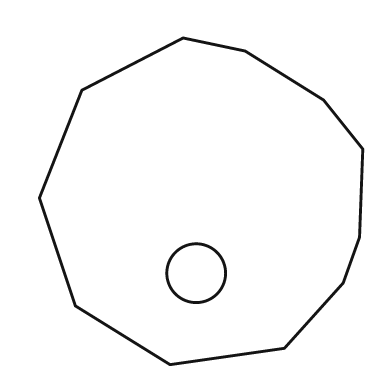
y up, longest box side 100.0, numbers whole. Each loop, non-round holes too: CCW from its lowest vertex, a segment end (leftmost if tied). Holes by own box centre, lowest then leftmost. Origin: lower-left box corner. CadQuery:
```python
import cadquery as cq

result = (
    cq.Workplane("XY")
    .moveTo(40.0, 0.0)
    .lineTo(75.0, 5.0)
    .lineTo(93.0, 25.0)
    .lineTo(98.0, 39.0)
    .lineTo(99.0, 66.0)
    .lineTo(87.0, 81.0)
    .lineTo(63.0, 96.0)
    .lineTo(44.0, 100.0)
    .lineTo(13.0, 84.0)
    .lineTo(0.0, 51.0)
    .lineTo(11.0, 18.0)
    .close()
    .moveTo(48.0, 28.0)
    .circle(9.0)
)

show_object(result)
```